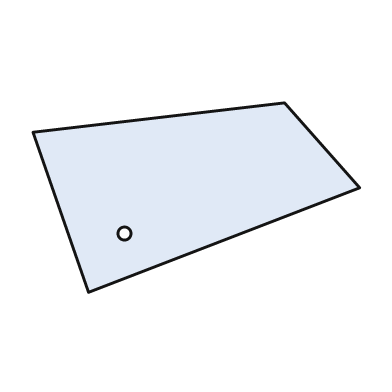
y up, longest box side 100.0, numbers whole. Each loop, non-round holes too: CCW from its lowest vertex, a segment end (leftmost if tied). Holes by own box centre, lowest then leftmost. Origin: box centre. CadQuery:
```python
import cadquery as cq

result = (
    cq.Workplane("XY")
    .moveTo(-33.0, -29.0)
    .lineTo(50.0, 3.0)
    .lineTo(27.0, 29.0)
    .lineTo(-50.0, 20.0)
    .close()
    .moveTo(-22.0, -11.0)
    .circle(2.0)
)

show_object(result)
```